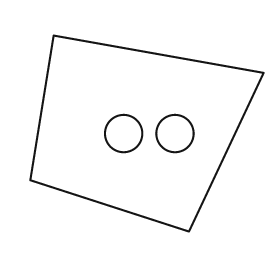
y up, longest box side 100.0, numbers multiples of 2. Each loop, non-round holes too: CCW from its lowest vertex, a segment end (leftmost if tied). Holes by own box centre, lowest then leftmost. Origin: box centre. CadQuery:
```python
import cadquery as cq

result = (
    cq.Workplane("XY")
    .moveTo(18.0, -42.0)
    .lineTo(50.0, 26.0)
    .lineTo(-40.0, 42.0)
    .lineTo(-50.0, -20.0)
    .close()
    .moveTo(-10.0, 0.0)
    .circle(8.0)
    .moveTo(12.0, 0.0)
    .circle(8.0)
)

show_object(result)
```